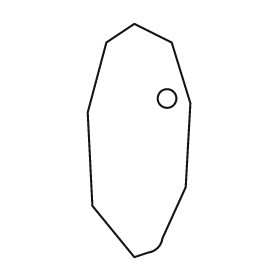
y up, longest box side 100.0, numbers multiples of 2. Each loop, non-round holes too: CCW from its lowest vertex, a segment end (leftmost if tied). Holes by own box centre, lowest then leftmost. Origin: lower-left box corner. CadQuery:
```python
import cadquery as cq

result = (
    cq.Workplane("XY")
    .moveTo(20.0, 0.0)
    .lineTo(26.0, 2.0)
    .threePointArc((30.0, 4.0), (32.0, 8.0))
    .lineTo(42.0, 30.0)
    .lineTo(44.0, 66.0)
    .lineTo(36.0, 92.0)
    .lineTo(20.0, 100.0)
    .lineTo(8.0, 92.0)
    .lineTo(0.0, 62.0)
    .lineTo(2.0, 22.0)
    .close()
    .moveTo(34.0, 68.0)
    .circle(4.0)
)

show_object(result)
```